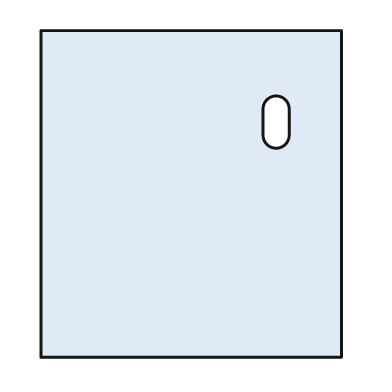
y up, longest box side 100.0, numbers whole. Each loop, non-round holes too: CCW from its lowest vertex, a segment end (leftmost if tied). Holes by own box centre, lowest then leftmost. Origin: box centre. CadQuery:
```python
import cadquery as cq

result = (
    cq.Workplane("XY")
    .moveTo(-46.0, -50.0)
    .lineTo(46.0, -50.0)
    .lineTo(46.0, 50.0)
    .lineTo(-46.0, 50.0)
    .close()
    .moveTo(22.0, 18.0)
    .threePointArc((26.0, 14.0), (30.0, 18.0))
    .lineTo(30.0, 26.0)
    .threePointArc((26.0, 30.0), (22.0, 26.0))
    .close()
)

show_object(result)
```